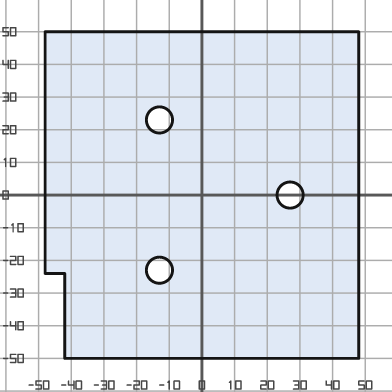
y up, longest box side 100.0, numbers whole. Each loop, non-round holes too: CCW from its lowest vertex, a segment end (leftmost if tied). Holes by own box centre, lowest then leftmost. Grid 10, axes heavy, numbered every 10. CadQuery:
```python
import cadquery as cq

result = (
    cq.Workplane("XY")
    .moveTo(-42.0, -50.0)
    .lineTo(48.0, -50.0)
    .lineTo(48.0, 50.0)
    .lineTo(-48.0, 50.0)
    .lineTo(-48.0, -24.0)
    .lineTo(-42.0, -24.0)
    .close()
    .moveTo(-13.0, -23.0)
    .circle(4.0)
    .moveTo(27.0, 0.0)
    .circle(4.0)
    .moveTo(-13.0, 23.0)
    .circle(4.0)
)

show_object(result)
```